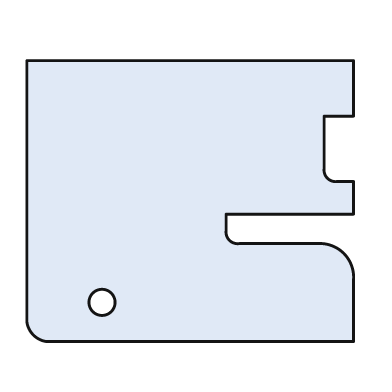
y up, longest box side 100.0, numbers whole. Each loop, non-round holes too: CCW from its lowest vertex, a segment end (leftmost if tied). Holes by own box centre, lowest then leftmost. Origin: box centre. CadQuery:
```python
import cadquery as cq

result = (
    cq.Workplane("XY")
    .moveTo(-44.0, -43.0)
    .lineTo(50.0, -43.0)
    .lineTo(50.0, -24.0)
    .threePointArc((47.0, -16.0), (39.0, -13.0))
    .lineTo(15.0, -13.0)
    .threePointArc((12.0, -12.0), (11.0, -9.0))
    .lineTo(11.0, -4.0)
    .lineTo(50.0, -4.0)
    .lineTo(50.0, 6.0)
    .lineTo(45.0, 6.0)
    .threePointArc((42.0, 7.0), (41.0, 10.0))
    .lineTo(41.0, 26.0)
    .lineTo(50.0, 26.0)
    .lineTo(50.0, 43.0)
    .lineTo(-50.0, 43.0)
    .lineTo(-50.0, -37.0)
    .threePointArc((-48.0, -41.0), (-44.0, -43.0))
    .close()
    .moveTo(-27.0, -31.0)
    .circle(4.0)
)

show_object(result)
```